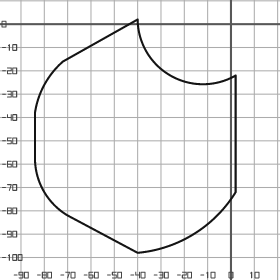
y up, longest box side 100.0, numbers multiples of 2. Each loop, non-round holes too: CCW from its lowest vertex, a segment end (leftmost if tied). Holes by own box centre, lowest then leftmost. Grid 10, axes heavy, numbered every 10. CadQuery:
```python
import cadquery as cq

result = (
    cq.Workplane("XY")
    .moveTo(-40.0, -98.0)
    .threePointArc((-16.0, -90.0), (2.0, -72.0))
    .lineTo(2.0, -22.0)
    .threePointArc((-26.0, -22.0), (-40.0, 2.0))
    .lineTo(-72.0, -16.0)
    .threePointArc((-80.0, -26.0), (-84.0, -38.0))
    .lineTo(-84.0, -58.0)
    .threePointArc((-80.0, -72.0), (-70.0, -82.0))
    .close()
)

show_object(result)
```